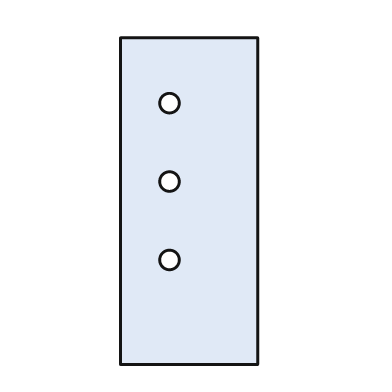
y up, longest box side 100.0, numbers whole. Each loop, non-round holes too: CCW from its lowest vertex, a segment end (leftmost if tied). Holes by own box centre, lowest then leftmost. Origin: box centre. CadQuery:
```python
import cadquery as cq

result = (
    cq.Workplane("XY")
    .moveTo(-21.0, -50.0)
    .lineTo(21.0, -50.0)
    .lineTo(21.0, 50.0)
    .lineTo(-21.0, 50.0)
    .close()
    .moveTo(-6.0, -18.0)
    .circle(3.0)
    .moveTo(-6.0, 6.0)
    .circle(3.0)
    .moveTo(-6.0, 30.0)
    .circle(3.0)
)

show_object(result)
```